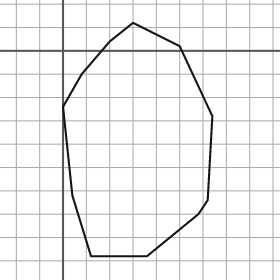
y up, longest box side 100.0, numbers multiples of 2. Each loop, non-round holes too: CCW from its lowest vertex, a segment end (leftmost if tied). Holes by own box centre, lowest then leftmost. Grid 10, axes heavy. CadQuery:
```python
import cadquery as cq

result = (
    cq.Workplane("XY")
    .moveTo(12.0, -88.0)
    .lineTo(36.0, -88.0)
    .lineTo(58.0, -70.0)
    .lineTo(62.0, -64.0)
    .lineTo(64.0, -28.0)
    .lineTo(50.0, 2.0)
    .lineTo(30.0, 12.0)
    .lineTo(20.0, 4.0)
    .lineTo(8.0, -10.0)
    .lineTo(0.0, -24.0)
    .lineTo(4.0, -62.0)
    .close()
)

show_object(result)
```